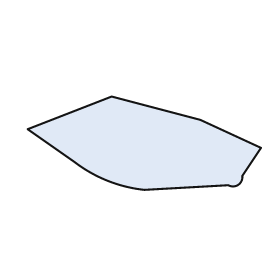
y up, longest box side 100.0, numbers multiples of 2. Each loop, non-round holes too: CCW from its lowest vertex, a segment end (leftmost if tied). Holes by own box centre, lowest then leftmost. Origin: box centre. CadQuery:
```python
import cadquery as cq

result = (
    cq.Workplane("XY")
    .moveTo(0.0, -20.0)
    .lineTo(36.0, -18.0)
    .threePointArc((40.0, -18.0), (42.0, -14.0))
    .lineTo(50.0, -2.0)
    .lineTo(24.0, 10.0)
    .lineTo(-14.0, 20.0)
    .lineTo(-50.0, 6.0)
    .lineTo(-30.0, -8.0)
    .threePointArc((-16.0, -16.0), (0.0, -20.0))
    .close()
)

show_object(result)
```